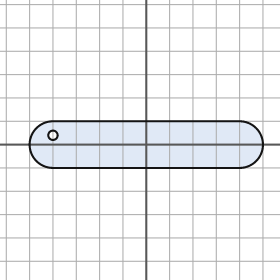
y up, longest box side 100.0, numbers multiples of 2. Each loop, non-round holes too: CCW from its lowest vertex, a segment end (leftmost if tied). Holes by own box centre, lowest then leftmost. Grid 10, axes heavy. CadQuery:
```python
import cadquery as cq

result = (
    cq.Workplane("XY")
    .moveTo(-40.0, -10.0)
    .lineTo(40.0, -10.0)
    .threePointArc((50.0, 0.0), (40.0, 10.0))
    .lineTo(-40.0, 10.0)
    .threePointArc((-50.0, 0.0), (-40.0, -10.0))
    .close()
    .moveTo(-40.0, 4.0)
    .circle(2.0)
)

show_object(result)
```